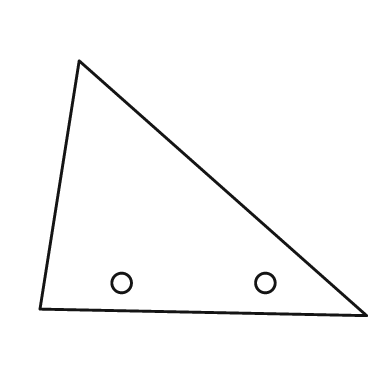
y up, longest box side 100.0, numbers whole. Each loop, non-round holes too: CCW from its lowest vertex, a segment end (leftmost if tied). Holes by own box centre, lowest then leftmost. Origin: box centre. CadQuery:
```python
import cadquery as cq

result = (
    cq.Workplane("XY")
    .moveTo(50.0, -39.0)
    .lineTo(-38.0, 39.0)
    .lineTo(-50.0, -37.0)
    .close()
    .moveTo(-25.0, -29.0)
    .circle(3.0)
    .moveTo(19.0, -29.0)
    .circle(3.0)
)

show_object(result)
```